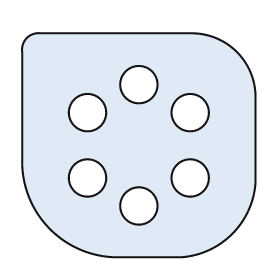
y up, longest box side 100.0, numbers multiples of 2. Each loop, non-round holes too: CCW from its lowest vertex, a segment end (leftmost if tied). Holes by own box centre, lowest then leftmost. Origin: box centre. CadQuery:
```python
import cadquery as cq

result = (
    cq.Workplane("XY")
    .moveTo(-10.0, -48.0)
    .lineTo(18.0, -48.0)
    .threePointArc((40.0, -38.0), (50.0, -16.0))
    .lineTo(50.0, 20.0)
    .threePointArc((42.0, 40.0), (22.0, 48.0))
    .lineTo(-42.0, 48.0)
    .threePointArc((-48.0, 46.0), (-50.0, 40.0))
    .lineTo(-50.0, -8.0)
    .threePointArc((-38.0, -36.0), (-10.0, -48.0))
    .close()
    .moveTo(0.0, -26.0)
    .circle(8.0)
    .moveTo(-22.0, -14.0)
    .circle(8.0)
    .moveTo(22.0, -14.0)
    .circle(8.0)
    .moveTo(-22.0, 14.0)
    .circle(8.0)
    .moveTo(22.0, 14.0)
    .circle(8.0)
    .moveTo(0.0, 26.0)
    .circle(8.0)
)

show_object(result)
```